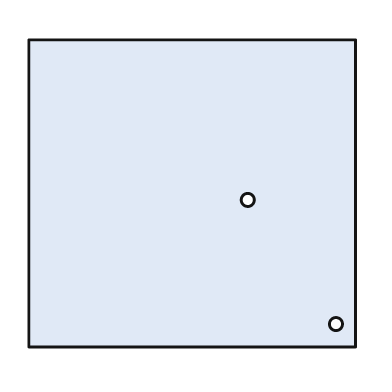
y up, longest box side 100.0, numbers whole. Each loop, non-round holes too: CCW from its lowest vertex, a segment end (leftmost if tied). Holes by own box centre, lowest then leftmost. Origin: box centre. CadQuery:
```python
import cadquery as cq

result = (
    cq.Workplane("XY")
    .moveTo(-50.0, -47.0)
    .lineTo(50.0, -47.0)
    .lineTo(50.0, 47.0)
    .lineTo(-50.0, 47.0)
    .close()
    .moveTo(44.0, -40.0)
    .circle(2.0)
    .moveTo(17.0, -2.0)
    .circle(2.0)
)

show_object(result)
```